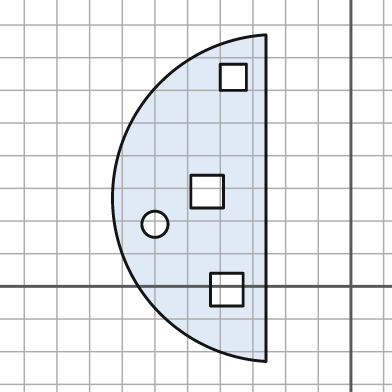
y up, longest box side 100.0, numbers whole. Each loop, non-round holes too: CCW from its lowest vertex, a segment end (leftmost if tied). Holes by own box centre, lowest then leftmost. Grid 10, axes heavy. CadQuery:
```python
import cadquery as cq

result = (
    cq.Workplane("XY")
    .moveTo(-26.0, -23.0)
    .lineTo(-26.0, 77.0)
    .threePointArc((-73.0, 27.0), (-26.0, -23.0))
    .close()
    .moveTo(-43.0, -6.0)
    .lineTo(-33.0, -6.0)
    .lineTo(-33.0, 4.0)
    .lineTo(-43.0, 4.0)
    .close()
    .moveTo(-60.0, 19.0)
    .circle(4.0)
    .moveTo(-49.0, 24.0)
    .lineTo(-39.0, 24.0)
    .lineTo(-39.0, 34.0)
    .lineTo(-49.0, 34.0)
    .close()
    .moveTo(-40.0, 60.0)
    .lineTo(-32.0, 60.0)
    .lineTo(-32.0, 68.0)
    .lineTo(-40.0, 68.0)
    .close()
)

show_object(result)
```